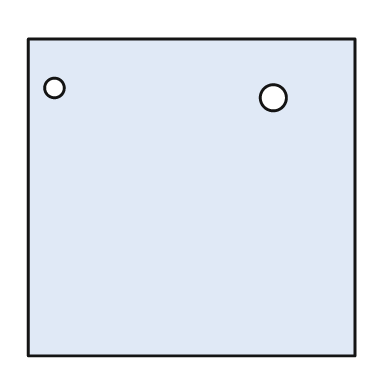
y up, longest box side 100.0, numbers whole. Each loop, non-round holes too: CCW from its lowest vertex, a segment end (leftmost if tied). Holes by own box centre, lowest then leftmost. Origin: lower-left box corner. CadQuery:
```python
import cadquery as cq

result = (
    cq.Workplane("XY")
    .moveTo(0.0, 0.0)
    .lineTo(100.0, 0.0)
    .lineTo(100.0, 97.0)
    .lineTo(0.0, 97.0)
    .close()
    .moveTo(75.0, 79.0)
    .circle(4.0)
    .moveTo(8.0, 82.0)
    .circle(3.0)
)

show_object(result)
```